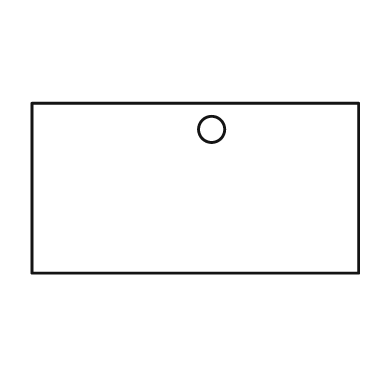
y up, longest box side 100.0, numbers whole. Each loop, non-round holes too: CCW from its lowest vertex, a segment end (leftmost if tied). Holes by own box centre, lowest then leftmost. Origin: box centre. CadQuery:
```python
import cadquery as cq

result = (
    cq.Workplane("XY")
    .moveTo(-50.0, -26.0)
    .lineTo(50.0, -26.0)
    .lineTo(50.0, 26.0)
    .lineTo(-50.0, 26.0)
    .close()
    .moveTo(5.0, 18.0)
    .circle(4.0)
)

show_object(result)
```